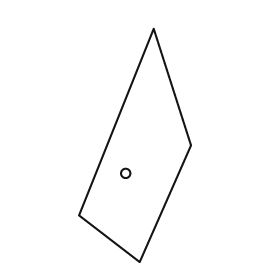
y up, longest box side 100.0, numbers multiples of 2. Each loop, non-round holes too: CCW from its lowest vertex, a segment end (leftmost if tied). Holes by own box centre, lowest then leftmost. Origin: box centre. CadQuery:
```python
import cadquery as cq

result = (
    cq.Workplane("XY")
    .moveTo(2.0, -50.0)
    .lineTo(24.0, 0.0)
    .lineTo(8.0, 50.0)
    .lineTo(-24.0, -30.0)
    .close()
    .moveTo(-4.0, -12.0)
    .circle(2.0)
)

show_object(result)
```